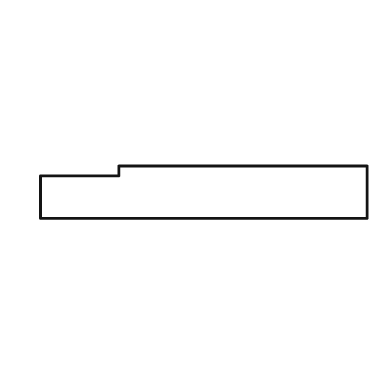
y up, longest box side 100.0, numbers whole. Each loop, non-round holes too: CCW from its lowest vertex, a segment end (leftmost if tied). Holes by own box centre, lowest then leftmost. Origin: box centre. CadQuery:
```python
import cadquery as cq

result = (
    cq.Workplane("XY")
    .moveTo(-50.0, -8.0)
    .lineTo(50.0, -8.0)
    .lineTo(50.0, 8.0)
    .lineTo(-26.0, 8.0)
    .lineTo(-26.0, 5.0)
    .lineTo(-50.0, 5.0)
    .close()
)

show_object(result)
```